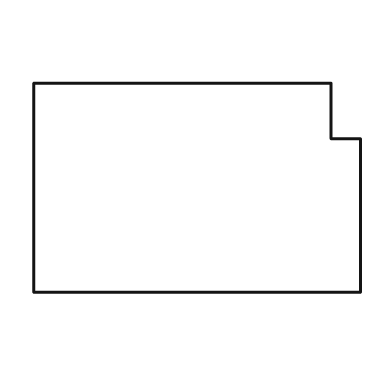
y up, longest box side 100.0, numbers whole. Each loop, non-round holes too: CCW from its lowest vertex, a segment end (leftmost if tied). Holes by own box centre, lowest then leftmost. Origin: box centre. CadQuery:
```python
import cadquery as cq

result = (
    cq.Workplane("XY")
    .moveTo(-50.0, -32.0)
    .lineTo(50.0, -32.0)
    .lineTo(50.0, 15.0)
    .lineTo(41.0, 15.0)
    .lineTo(41.0, 32.0)
    .lineTo(-50.0, 32.0)
    .close()
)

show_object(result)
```